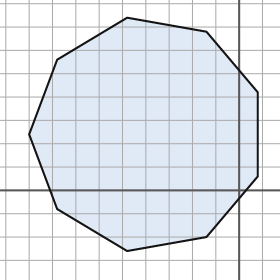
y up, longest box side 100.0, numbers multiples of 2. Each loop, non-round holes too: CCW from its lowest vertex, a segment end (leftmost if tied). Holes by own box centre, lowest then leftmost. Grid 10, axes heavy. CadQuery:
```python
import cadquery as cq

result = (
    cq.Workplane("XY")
    .moveTo(-48.0, -26.0)
    .lineTo(-14.0, -20.0)
    .lineTo(8.0, 6.0)
    .lineTo(8.0, 42.0)
    .lineTo(-14.0, 68.0)
    .lineTo(-48.0, 74.0)
    .lineTo(-78.0, 56.0)
    .lineTo(-90.0, 24.0)
    .lineTo(-78.0, -8.0)
    .close()
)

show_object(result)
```